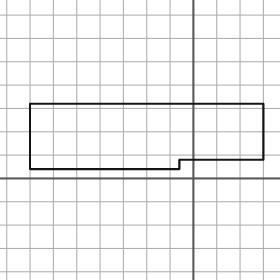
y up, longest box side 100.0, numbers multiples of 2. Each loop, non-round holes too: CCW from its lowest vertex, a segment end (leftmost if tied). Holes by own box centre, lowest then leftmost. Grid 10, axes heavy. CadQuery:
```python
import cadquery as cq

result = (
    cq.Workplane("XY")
    .moveTo(-70.0, 4.0)
    .lineTo(-6.0, 4.0)
    .lineTo(-6.0, 8.0)
    .lineTo(30.0, 8.0)
    .lineTo(30.0, 32.0)
    .lineTo(-70.0, 32.0)
    .close()
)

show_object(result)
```